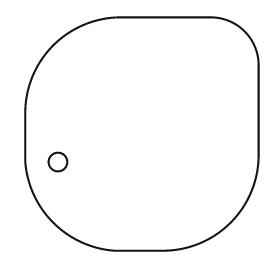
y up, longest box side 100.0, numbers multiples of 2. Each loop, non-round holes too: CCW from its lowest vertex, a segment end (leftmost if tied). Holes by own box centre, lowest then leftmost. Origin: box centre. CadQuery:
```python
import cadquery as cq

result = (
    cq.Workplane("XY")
    .moveTo(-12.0, -50.0)
    .lineTo(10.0, -50.0)
    .threePointArc((38.0, -38.0), (50.0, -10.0))
    .lineTo(50.0, 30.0)
    .threePointArc((44.0, 44.0), (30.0, 50.0))
    .lineTo(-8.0, 50.0)
    .threePointArc((-38.0, 38.0), (-50.0, 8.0))
    .lineTo(-50.0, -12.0)
    .threePointArc((-38.0, -38.0), (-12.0, -50.0))
    .close()
    .moveTo(-36.0, -12.0)
    .circle(4.0)
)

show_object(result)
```